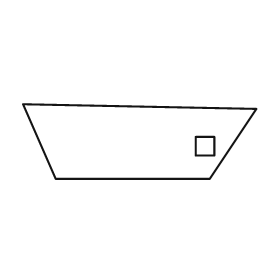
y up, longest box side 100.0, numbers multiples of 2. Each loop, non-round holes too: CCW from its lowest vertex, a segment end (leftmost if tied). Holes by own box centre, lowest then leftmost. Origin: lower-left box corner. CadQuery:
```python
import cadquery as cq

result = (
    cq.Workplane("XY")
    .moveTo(14.0, 0.0)
    .lineTo(80.0, 0.0)
    .lineTo(100.0, 30.0)
    .lineTo(0.0, 32.0)
    .close()
    .moveTo(74.0, 10.0)
    .lineTo(82.0, 10.0)
    .lineTo(82.0, 18.0)
    .lineTo(74.0, 18.0)
    .close()
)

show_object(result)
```